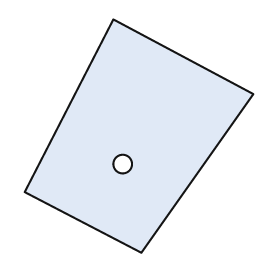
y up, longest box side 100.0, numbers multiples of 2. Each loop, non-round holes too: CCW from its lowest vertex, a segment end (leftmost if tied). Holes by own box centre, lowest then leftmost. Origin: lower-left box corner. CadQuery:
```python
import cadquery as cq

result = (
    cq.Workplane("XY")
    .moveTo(50.0, 0.0)
    .lineTo(98.0, 68.0)
    .lineTo(38.0, 100.0)
    .lineTo(0.0, 26.0)
    .close()
    .moveTo(42.0, 38.0)
    .circle(4.0)
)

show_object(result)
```